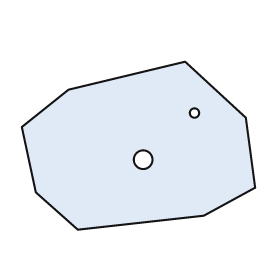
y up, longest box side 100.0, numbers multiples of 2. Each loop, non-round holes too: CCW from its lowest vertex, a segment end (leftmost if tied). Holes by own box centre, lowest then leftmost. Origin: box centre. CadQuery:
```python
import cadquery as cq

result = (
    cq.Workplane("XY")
    .moveTo(-26.0, -36.0)
    .lineTo(28.0, -30.0)
    .lineTo(50.0, -18.0)
    .lineTo(46.0, 12.0)
    .lineTo(20.0, 36.0)
    .lineTo(-30.0, 24.0)
    .lineTo(-50.0, 8.0)
    .lineTo(-44.0, -20.0)
    .close()
    .moveTo(2.0, -6.0)
    .circle(4.0)
    .moveTo(24.0, 14.0)
    .circle(2.0)
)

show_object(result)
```